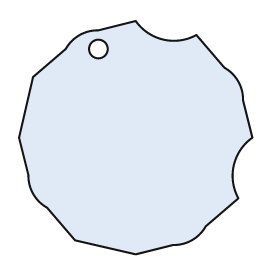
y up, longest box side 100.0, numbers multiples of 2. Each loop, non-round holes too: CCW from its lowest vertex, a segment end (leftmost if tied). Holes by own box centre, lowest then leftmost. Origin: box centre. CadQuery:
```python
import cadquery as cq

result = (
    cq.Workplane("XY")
    .moveTo(0.0, -50.0)
    .lineTo(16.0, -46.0)
    .threePointArc((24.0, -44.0), (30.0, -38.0))
    .lineTo(44.0, -26.0)
    .threePointArc((42.0, -12.0), (50.0, 0.0))
    .lineTo(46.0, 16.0)
    .threePointArc((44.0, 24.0), (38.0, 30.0))
    .lineTo(26.0, 44.0)
    .threePointArc((12.0, 42.0), (0.0, 50.0))
    .lineTo(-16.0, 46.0)
    .threePointArc((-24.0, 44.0), (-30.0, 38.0))
    .lineTo(-44.0, 26.0)
    .lineTo(-50.0, 0.0)
    .lineTo(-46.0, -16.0)
    .threePointArc((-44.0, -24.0), (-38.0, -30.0))
    .lineTo(-26.0, -44.0)
    .close()
    .moveTo(-16.0, 38.0)
    .circle(4.0)
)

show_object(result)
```